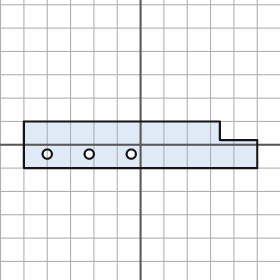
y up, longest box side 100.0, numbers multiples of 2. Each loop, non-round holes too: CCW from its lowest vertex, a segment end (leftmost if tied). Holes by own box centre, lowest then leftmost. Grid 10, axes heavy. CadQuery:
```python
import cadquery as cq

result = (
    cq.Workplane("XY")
    .moveTo(-50.0, -10.0)
    .lineTo(50.0, -10.0)
    .lineTo(50.0, 2.0)
    .lineTo(34.0, 2.0)
    .lineTo(34.0, 10.0)
    .lineTo(-50.0, 10.0)
    .close()
    .moveTo(-40.0, -4.0)
    .circle(2.0)
    .moveTo(-22.0, -4.0)
    .circle(2.0)
    .moveTo(-4.0, -4.0)
    .circle(2.0)
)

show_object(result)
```